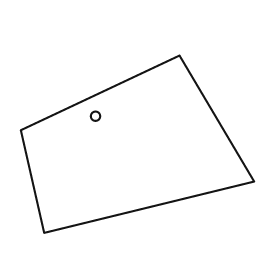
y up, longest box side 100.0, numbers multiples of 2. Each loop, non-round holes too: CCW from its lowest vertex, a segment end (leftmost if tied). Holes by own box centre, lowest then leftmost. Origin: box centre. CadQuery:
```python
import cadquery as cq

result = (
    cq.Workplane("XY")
    .moveTo(-40.0, -38.0)
    .lineTo(50.0, -16.0)
    .lineTo(18.0, 38.0)
    .lineTo(-50.0, 6.0)
    .close()
    .moveTo(-18.0, 12.0)
    .circle(2.0)
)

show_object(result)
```